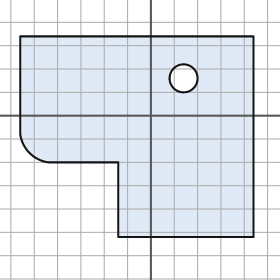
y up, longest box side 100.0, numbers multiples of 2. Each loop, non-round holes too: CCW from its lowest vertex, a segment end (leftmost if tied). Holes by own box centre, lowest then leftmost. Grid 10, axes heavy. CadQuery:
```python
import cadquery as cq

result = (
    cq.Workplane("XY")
    .moveTo(-14.0, -52.0)
    .lineTo(44.0, -52.0)
    .lineTo(44.0, 34.0)
    .lineTo(-56.0, 34.0)
    .lineTo(-56.0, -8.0)
    .threePointArc((-52.0, -16.0), (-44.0, -20.0))
    .lineTo(-14.0, -20.0)
    .close()
    .moveTo(14.0, 16.0)
    .circle(6.0)
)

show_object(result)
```